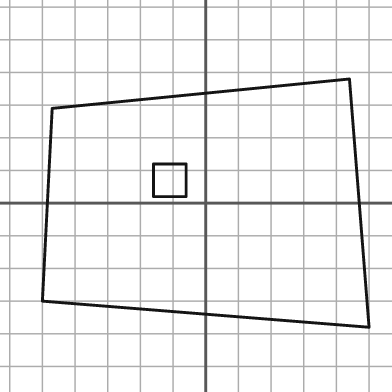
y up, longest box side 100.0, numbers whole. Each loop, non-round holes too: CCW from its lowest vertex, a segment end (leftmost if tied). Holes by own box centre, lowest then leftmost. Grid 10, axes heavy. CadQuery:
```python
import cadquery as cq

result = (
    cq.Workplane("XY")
    .moveTo(50.0, -38.0)
    .lineTo(44.0, 38.0)
    .lineTo(-47.0, 29.0)
    .lineTo(-50.0, -30.0)
    .close()
    .moveTo(-16.0, 2.0)
    .lineTo(-6.0, 2.0)
    .lineTo(-6.0, 12.0)
    .lineTo(-16.0, 12.0)
    .close()
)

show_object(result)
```